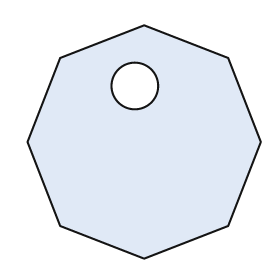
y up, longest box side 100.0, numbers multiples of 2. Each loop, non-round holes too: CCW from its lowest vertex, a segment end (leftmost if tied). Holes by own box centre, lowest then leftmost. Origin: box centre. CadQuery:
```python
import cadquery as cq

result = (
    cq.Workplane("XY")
    .moveTo(0.0, -50.0)
    .lineTo(36.0, -36.0)
    .lineTo(50.0, 0.0)
    .lineTo(36.0, 36.0)
    .lineTo(0.0, 50.0)
    .lineTo(-36.0, 36.0)
    .lineTo(-50.0, 0.0)
    .lineTo(-36.0, -36.0)
    .close()
    .moveTo(-4.0, 24.0)
    .circle(10.0)
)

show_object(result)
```